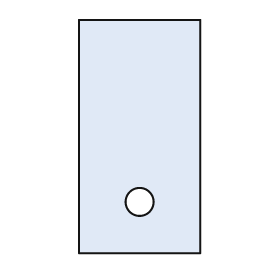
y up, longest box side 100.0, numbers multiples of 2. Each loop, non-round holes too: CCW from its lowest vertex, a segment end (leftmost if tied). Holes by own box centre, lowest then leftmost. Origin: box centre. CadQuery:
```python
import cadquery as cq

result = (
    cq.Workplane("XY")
    .moveTo(-26.0, -50.0)
    .lineTo(26.0, -50.0)
    .lineTo(26.0, 50.0)
    .lineTo(-26.0, 50.0)
    .close()
    .moveTo(0.0, -28.0)
    .circle(6.0)
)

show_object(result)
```